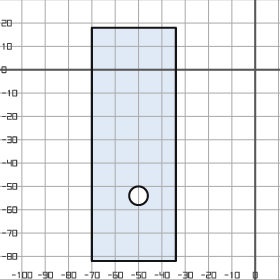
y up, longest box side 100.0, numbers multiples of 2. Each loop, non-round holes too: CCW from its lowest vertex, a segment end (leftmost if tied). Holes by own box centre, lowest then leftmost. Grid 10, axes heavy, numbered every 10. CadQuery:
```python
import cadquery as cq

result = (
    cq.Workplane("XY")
    .moveTo(-70.0, -82.0)
    .lineTo(-34.0, -82.0)
    .lineTo(-34.0, 18.0)
    .lineTo(-70.0, 18.0)
    .close()
    .moveTo(-50.0, -54.0)
    .circle(4.0)
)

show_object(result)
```